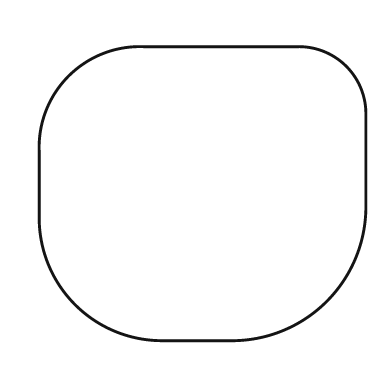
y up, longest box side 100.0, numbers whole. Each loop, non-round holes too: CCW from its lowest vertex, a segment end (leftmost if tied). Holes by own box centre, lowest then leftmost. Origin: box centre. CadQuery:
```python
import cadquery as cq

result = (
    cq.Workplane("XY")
    .moveTo(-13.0, -45.0)
    .lineTo(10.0, -45.0)
    .threePointArc((38.0, -33.0), (50.0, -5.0))
    .lineTo(50.0, 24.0)
    .threePointArc((44.0, 39.0), (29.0, 45.0))
    .lineTo(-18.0, 45.0)
    .threePointArc((-41.0, 36.0), (-50.0, 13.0))
    .lineTo(-50.0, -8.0)
    .threePointArc((-39.0, -34.0), (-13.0, -45.0))
    .close()
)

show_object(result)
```